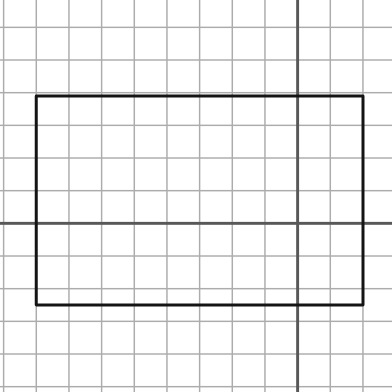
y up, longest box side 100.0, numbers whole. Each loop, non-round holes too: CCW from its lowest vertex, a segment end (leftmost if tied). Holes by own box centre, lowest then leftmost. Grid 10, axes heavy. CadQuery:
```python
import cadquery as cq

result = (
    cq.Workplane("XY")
    .moveTo(-80.0, -25.0)
    .lineTo(20.0, -25.0)
    .lineTo(20.0, 39.0)
    .lineTo(-80.0, 39.0)
    .close()
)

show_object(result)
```